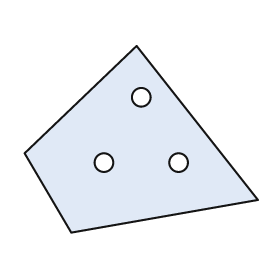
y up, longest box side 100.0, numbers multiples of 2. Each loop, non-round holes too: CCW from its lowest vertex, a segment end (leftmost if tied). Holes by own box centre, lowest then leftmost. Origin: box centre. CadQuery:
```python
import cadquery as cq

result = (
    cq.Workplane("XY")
    .moveTo(-30.0, -40.0)
    .lineTo(50.0, -26.0)
    .lineTo(-2.0, 40.0)
    .lineTo(-50.0, -6.0)
    .close()
    .moveTo(-16.0, -10.0)
    .circle(4.0)
    .moveTo(16.0, -10.0)
    .circle(4.0)
    .moveTo(0.0, 18.0)
    .circle(4.0)
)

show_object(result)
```